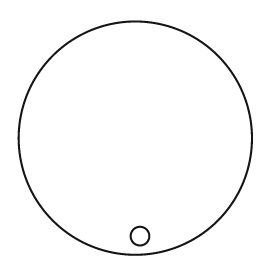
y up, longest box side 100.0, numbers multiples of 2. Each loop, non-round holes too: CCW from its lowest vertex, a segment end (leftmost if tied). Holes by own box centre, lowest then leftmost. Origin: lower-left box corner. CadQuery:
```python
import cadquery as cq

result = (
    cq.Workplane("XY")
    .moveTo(50.0, 50.0)
    .circle(50.0)
    .moveTo(52.0, 8.0)
    .circle(4.0)
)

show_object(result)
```